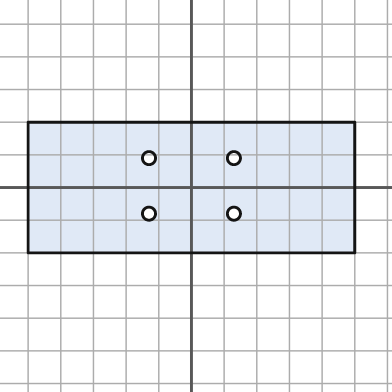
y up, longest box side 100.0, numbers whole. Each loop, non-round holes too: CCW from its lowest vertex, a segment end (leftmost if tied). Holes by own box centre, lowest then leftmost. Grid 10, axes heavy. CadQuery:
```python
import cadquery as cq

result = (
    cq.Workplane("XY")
    .moveTo(-50.0, -20.0)
    .lineTo(50.0, -20.0)
    .lineTo(50.0, 20.0)
    .lineTo(-50.0, 20.0)
    .close()
    .moveTo(-13.0, -8.0)
    .circle(2.0)
    .moveTo(13.0, -8.0)
    .circle(2.0)
    .moveTo(-13.0, 9.0)
    .circle(2.0)
    .moveTo(13.0, 9.0)
    .circle(2.0)
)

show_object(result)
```